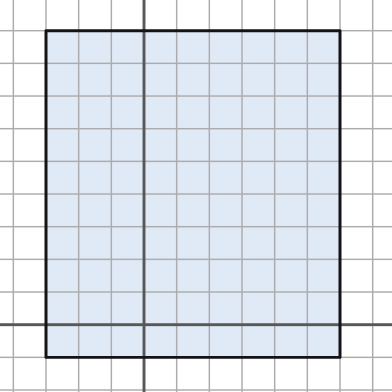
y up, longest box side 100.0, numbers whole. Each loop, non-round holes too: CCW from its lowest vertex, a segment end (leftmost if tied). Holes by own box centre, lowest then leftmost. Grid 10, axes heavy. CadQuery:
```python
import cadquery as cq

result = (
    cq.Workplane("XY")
    .moveTo(-30.0, -10.0)
    .lineTo(60.0, -10.0)
    .lineTo(60.0, 90.0)
    .lineTo(-30.0, 90.0)
    .close()
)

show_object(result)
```